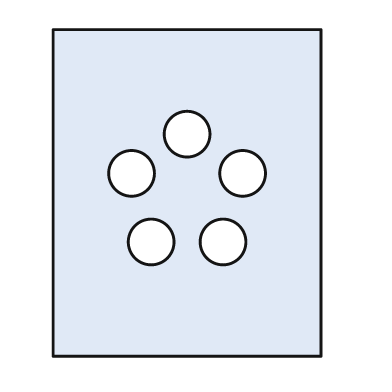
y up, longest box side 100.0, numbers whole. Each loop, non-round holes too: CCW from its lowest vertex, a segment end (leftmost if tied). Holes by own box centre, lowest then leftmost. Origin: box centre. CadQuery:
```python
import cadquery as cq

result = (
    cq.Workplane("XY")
    .moveTo(-41.0, -50.0)
    .lineTo(41.0, -50.0)
    .lineTo(41.0, 50.0)
    .lineTo(-41.0, 50.0)
    .close()
    .moveTo(-11.0, -15.0)
    .circle(7.0)
    .moveTo(11.0, -15.0)
    .circle(7.0)
    .moveTo(-17.0, 6.0)
    .circle(7.0)
    .moveTo(17.0, 6.0)
    .circle(7.0)
    .moveTo(0.0, 18.0)
    .circle(7.0)
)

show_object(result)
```